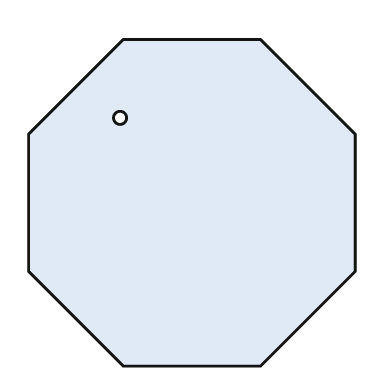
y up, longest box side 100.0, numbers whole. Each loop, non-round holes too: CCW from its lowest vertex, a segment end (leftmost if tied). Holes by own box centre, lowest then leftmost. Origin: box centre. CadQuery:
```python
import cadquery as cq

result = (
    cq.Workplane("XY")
    .moveTo(-21.0, -50.0)
    .lineTo(21.0, -50.0)
    .lineTo(50.0, -21.0)
    .lineTo(50.0, 21.0)
    .lineTo(21.0, 50.0)
    .lineTo(-21.0, 50.0)
    .lineTo(-50.0, 21.0)
    .lineTo(-50.0, -21.0)
    .close()
    .moveTo(-22.0, 26.0)
    .circle(2.0)
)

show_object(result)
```